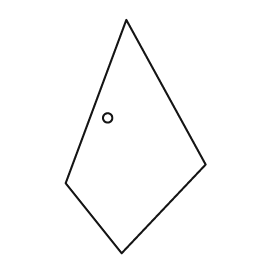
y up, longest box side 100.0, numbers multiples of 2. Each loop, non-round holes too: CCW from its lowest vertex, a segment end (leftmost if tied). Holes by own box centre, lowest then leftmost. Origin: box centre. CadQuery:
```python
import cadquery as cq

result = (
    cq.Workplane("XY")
    .moveTo(-6.0, -50.0)
    .lineTo(30.0, -12.0)
    .lineTo(-4.0, 50.0)
    .lineTo(-30.0, -20.0)
    .close()
    .moveTo(-12.0, 8.0)
    .circle(2.0)
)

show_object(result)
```